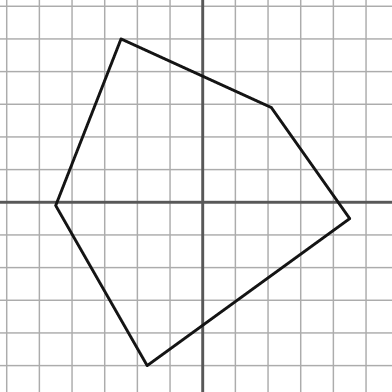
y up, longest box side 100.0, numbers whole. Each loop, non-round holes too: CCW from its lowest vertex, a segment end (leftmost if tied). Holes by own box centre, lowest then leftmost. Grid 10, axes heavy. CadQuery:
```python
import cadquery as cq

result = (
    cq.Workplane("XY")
    .moveTo(-17.0, -50.0)
    .lineTo(45.0, -5.0)
    .lineTo(21.0, 29.0)
    .lineTo(-25.0, 50.0)
    .lineTo(-45.0, -1.0)
    .close()
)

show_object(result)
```